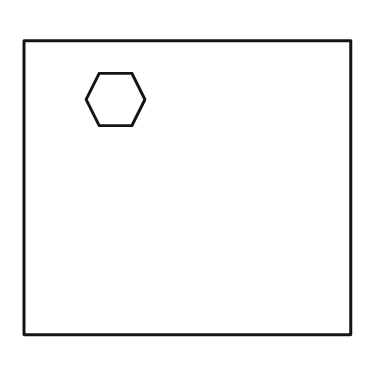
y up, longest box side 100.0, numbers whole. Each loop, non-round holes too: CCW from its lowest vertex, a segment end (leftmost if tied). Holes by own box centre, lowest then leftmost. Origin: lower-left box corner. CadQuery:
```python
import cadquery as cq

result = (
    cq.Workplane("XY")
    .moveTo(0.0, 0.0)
    .lineTo(100.0, 0.0)
    .lineTo(100.0, 90.0)
    .lineTo(0.0, 90.0)
    .close()
    .moveTo(23.0, 64.0)
    .lineTo(33.0, 64.0)
    .lineTo(37.0, 72.0)
    .lineTo(33.0, 80.0)
    .lineTo(23.0, 80.0)
    .lineTo(19.0, 72.0)
    .close()
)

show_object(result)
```